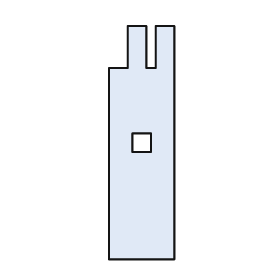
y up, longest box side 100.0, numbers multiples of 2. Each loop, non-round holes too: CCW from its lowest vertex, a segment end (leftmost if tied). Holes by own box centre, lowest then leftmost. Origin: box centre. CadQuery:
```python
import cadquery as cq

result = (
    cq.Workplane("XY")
    .moveTo(-14.0, -50.0)
    .lineTo(14.0, -50.0)
    .lineTo(14.0, 50.0)
    .lineTo(6.0, 50.0)
    .lineTo(6.0, 32.0)
    .lineTo(2.0, 32.0)
    .lineTo(2.0, 50.0)
    .lineTo(-6.0, 50.0)
    .lineTo(-6.0, 32.0)
    .lineTo(-14.0, 32.0)
    .close()
    .moveTo(-4.0, -4.0)
    .lineTo(4.0, -4.0)
    .lineTo(4.0, 4.0)
    .lineTo(-4.0, 4.0)
    .close()
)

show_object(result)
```